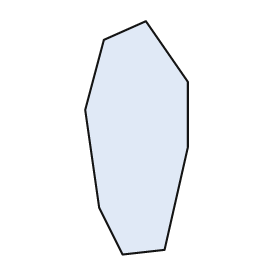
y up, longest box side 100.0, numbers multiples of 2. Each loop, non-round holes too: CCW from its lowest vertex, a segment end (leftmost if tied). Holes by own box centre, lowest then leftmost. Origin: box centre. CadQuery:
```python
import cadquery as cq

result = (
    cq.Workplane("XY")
    .moveTo(-6.0, -50.0)
    .lineTo(12.0, -48.0)
    .lineTo(22.0, -4.0)
    .lineTo(22.0, 24.0)
    .lineTo(4.0, 50.0)
    .lineTo(-14.0, 42.0)
    .lineTo(-22.0, 12.0)
    .lineTo(-16.0, -30.0)
    .close()
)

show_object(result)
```